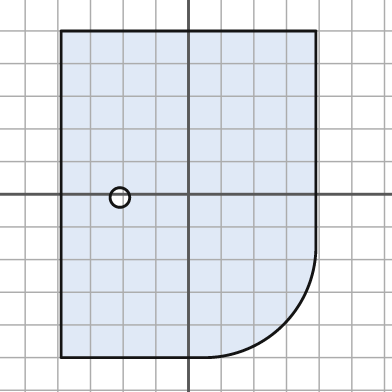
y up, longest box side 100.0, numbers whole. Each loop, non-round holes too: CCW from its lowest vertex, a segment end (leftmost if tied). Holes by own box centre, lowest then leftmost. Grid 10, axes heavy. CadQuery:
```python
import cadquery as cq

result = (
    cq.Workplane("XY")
    .moveTo(-39.0, -50.0)
    .lineTo(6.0, -50.0)
    .threePointArc((29.0, -40.0), (39.0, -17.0))
    .lineTo(39.0, 50.0)
    .lineTo(-39.0, 50.0)
    .close()
    .moveTo(-21.0, -1.0)
    .circle(3.0)
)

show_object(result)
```